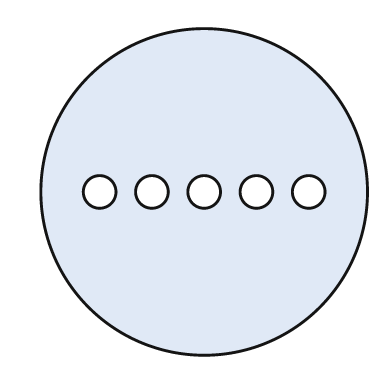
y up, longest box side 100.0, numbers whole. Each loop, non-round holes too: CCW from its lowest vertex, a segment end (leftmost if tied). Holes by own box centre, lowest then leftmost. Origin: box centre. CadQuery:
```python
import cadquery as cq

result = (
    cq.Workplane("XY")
    .moveTo(0.0, 0.0)
    .circle(50.0)
    .moveTo(-32.0, 0.0)
    .circle(5.0)
    .moveTo(-16.0, 0.0)
    .circle(5.0)
    .moveTo(0.0, 0.0)
    .circle(5.0)
    .moveTo(16.0, 0.0)
    .circle(5.0)
    .moveTo(32.0, 0.0)
    .circle(5.0)
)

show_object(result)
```